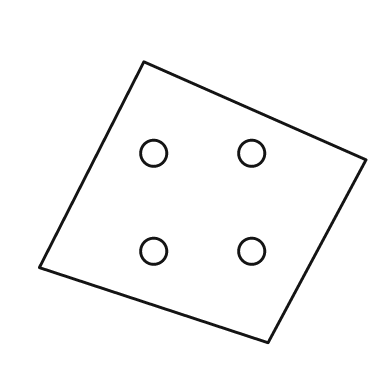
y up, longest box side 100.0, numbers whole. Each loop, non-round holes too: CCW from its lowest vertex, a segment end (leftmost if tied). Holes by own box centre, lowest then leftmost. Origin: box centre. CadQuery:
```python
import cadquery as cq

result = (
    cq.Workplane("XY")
    .moveTo(20.0, -43.0)
    .lineTo(50.0, 13.0)
    .lineTo(-18.0, 43.0)
    .lineTo(-50.0, -20.0)
    .close()
    .moveTo(-15.0, -15.0)
    .circle(4.0)
    .moveTo(15.0, -15.0)
    .circle(4.0)
    .moveTo(-15.0, 15.0)
    .circle(4.0)
    .moveTo(15.0, 15.0)
    .circle(4.0)
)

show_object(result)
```